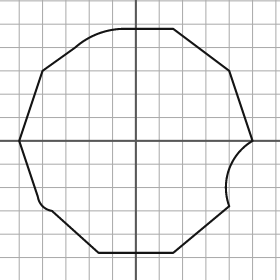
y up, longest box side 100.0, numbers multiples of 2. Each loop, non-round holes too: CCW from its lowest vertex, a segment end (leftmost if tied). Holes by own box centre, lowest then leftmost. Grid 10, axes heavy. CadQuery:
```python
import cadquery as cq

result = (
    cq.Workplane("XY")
    .moveTo(-16.0, -48.0)
    .lineTo(16.0, -48.0)
    .lineTo(40.0, -28.0)
    .threePointArc((40.0, -12.0), (50.0, 0.0))
    .lineTo(40.0, 30.0)
    .lineTo(16.0, 48.0)
    .lineTo(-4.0, 48.0)
    .threePointArc((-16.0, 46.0), (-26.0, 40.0))
    .lineTo(-40.0, 30.0)
    .lineTo(-50.0, 0.0)
    .lineTo(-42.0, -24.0)
    .threePointArc((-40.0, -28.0), (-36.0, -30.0))
    .close()
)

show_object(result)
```